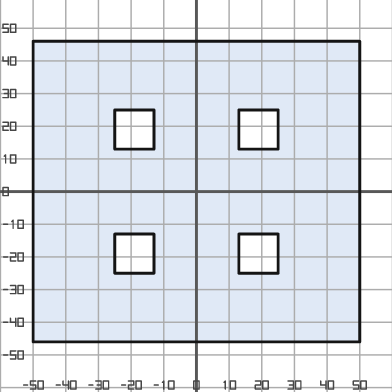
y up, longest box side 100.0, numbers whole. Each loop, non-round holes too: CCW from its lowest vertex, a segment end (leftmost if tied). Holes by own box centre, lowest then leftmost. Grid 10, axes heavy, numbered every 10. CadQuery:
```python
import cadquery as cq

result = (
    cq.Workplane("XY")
    .moveTo(-50.0, -46.0)
    .lineTo(50.0, -46.0)
    .lineTo(50.0, 46.0)
    .lineTo(-50.0, 46.0)
    .close()
    .moveTo(-25.0, -25.0)
    .lineTo(-13.0, -25.0)
    .lineTo(-13.0, -13.0)
    .lineTo(-25.0, -13.0)
    .close()
    .moveTo(13.0, -25.0)
    .lineTo(25.0, -25.0)
    .lineTo(25.0, -13.0)
    .lineTo(13.0, -13.0)
    .close()
    .moveTo(-25.0, 13.0)
    .lineTo(-13.0, 13.0)
    .lineTo(-13.0, 25.0)
    .lineTo(-25.0, 25.0)
    .close()
    .moveTo(13.0, 13.0)
    .lineTo(25.0, 13.0)
    .lineTo(25.0, 25.0)
    .lineTo(13.0, 25.0)
    .close()
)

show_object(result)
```